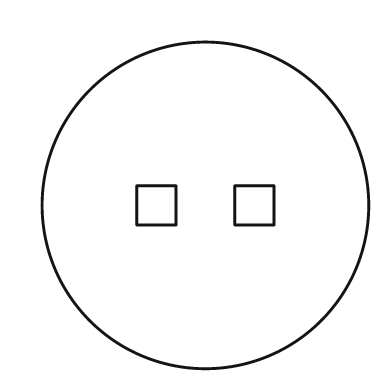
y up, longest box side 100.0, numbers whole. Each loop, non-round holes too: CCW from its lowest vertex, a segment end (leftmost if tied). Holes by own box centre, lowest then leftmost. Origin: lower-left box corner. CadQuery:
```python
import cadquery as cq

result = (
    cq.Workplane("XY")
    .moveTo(50.0, 50.0)
    .circle(50.0)
    .moveTo(29.0, 44.0)
    .lineTo(41.0, 44.0)
    .lineTo(41.0, 56.0)
    .lineTo(29.0, 56.0)
    .close()
    .moveTo(59.0, 44.0)
    .lineTo(71.0, 44.0)
    .lineTo(71.0, 56.0)
    .lineTo(59.0, 56.0)
    .close()
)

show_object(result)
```